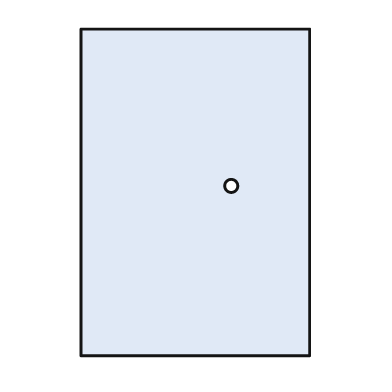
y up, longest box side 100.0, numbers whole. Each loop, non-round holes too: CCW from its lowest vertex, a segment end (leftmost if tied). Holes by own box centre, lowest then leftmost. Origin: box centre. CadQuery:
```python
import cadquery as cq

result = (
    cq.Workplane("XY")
    .moveTo(-35.0, -50.0)
    .lineTo(35.0, -50.0)
    .lineTo(35.0, 50.0)
    .lineTo(-35.0, 50.0)
    .close()
    .moveTo(11.0, 2.0)
    .circle(2.0)
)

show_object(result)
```